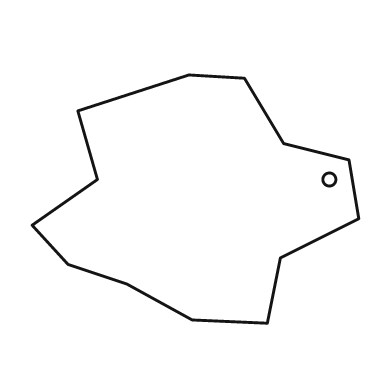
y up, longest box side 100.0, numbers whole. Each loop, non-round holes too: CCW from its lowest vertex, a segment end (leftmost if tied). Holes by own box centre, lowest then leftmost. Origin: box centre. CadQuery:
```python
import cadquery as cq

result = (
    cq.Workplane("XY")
    .moveTo(22.0, -38.0)
    .lineTo(26.0, -18.0)
    .lineTo(50.0, -6.0)
    .lineTo(47.0, 12.0)
    .lineTo(27.0, 17.0)
    .lineTo(15.0, 37.0)
    .lineTo(-2.0, 38.0)
    .lineTo(-36.0, 27.0)
    .lineTo(-30.0, 6.0)
    .lineTo(-50.0, -8.0)
    .lineTo(-39.0, -20.0)
    .lineTo(-21.0, -26.0)
    .lineTo(-1.0, -37.0)
    .close()
    .moveTo(41.0, 6.0)
    .circle(2.0)
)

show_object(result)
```